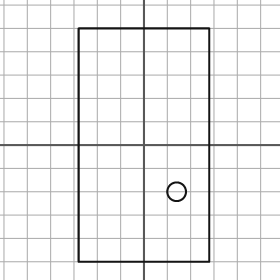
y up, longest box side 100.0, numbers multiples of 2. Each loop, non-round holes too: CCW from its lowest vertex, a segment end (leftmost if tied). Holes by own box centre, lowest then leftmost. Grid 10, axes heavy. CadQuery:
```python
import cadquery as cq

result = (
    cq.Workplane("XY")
    .moveTo(-28.0, -50.0)
    .lineTo(28.0, -50.0)
    .lineTo(28.0, 50.0)
    .lineTo(-28.0, 50.0)
    .close()
    .moveTo(14.0, -20.0)
    .circle(4.0)
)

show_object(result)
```